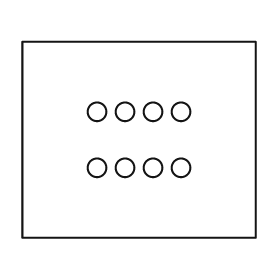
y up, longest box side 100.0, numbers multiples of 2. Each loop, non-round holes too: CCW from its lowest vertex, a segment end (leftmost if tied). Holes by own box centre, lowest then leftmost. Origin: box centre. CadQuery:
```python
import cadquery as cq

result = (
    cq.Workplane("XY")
    .moveTo(-50.0, -42.0)
    .lineTo(50.0, -42.0)
    .lineTo(50.0, 42.0)
    .lineTo(-50.0, 42.0)
    .close()
    .moveTo(-18.0, -12.0)
    .circle(4.0)
    .moveTo(-6.0, -12.0)
    .circle(4.0)
    .moveTo(6.0, -12.0)
    .circle(4.0)
    .moveTo(18.0, -12.0)
    .circle(4.0)
    .moveTo(-18.0, 12.0)
    .circle(4.0)
    .moveTo(-6.0, 12.0)
    .circle(4.0)
    .moveTo(6.0, 12.0)
    .circle(4.0)
    .moveTo(18.0, 12.0)
    .circle(4.0)
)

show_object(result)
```